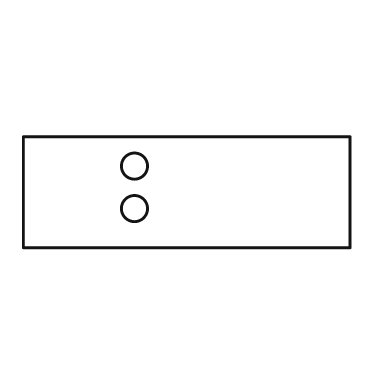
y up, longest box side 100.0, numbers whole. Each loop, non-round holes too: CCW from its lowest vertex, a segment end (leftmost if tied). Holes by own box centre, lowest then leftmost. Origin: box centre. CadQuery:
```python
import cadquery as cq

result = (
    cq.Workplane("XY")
    .moveTo(-50.0, -17.0)
    .lineTo(50.0, -17.0)
    .lineTo(50.0, 17.0)
    .lineTo(-50.0, 17.0)
    .close()
    .moveTo(-16.0, -5.0)
    .circle(4.0)
    .moveTo(-16.0, 8.0)
    .circle(4.0)
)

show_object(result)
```